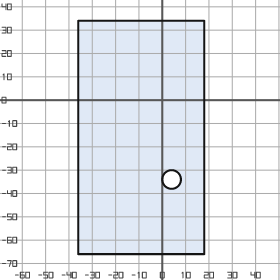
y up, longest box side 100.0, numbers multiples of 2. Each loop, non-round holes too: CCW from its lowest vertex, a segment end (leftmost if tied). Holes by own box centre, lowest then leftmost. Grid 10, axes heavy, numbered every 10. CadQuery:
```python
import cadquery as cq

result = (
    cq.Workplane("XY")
    .moveTo(-36.0, -66.0)
    .lineTo(18.0, -66.0)
    .lineTo(18.0, 34.0)
    .lineTo(-36.0, 34.0)
    .close()
    .moveTo(4.0, -34.0)
    .circle(4.0)
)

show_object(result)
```